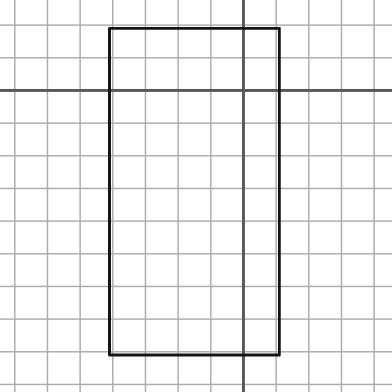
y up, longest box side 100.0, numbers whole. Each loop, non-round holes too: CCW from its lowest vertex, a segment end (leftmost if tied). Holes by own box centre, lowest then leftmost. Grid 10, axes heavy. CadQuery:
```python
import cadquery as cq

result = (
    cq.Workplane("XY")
    .moveTo(-41.0, -81.0)
    .lineTo(11.0, -81.0)
    .lineTo(11.0, 19.0)
    .lineTo(-41.0, 19.0)
    .close()
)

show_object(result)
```